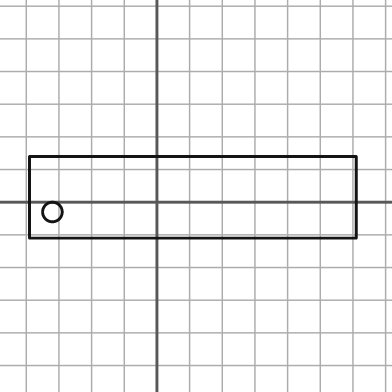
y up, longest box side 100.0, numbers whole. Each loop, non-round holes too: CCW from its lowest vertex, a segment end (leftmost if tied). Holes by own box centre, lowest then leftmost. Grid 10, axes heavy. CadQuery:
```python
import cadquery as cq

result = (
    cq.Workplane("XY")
    .moveTo(-39.0, -11.0)
    .lineTo(61.0, -11.0)
    .lineTo(61.0, 14.0)
    .lineTo(-39.0, 14.0)
    .close()
    .moveTo(-32.0, -3.0)
    .circle(3.0)
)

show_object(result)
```